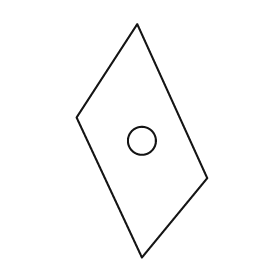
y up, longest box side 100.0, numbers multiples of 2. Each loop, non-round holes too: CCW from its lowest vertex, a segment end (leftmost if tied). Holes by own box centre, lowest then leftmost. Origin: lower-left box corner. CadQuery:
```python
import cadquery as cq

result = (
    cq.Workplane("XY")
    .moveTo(28.0, 0.0)
    .lineTo(56.0, 34.0)
    .lineTo(26.0, 100.0)
    .lineTo(0.0, 60.0)
    .close()
    .moveTo(28.0, 50.0)
    .circle(6.0)
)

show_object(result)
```